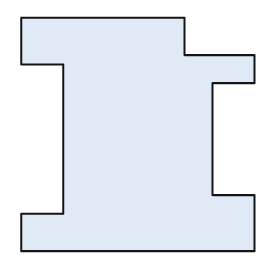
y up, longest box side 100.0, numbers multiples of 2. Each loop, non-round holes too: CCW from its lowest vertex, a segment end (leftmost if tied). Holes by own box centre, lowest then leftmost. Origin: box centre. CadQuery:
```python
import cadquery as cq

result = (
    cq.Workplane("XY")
    .moveTo(-50.0, -50.0)
    .lineTo(50.0, -50.0)
    .lineTo(50.0, -26.0)
    .lineTo(32.0, -26.0)
    .lineTo(32.0, 22.0)
    .lineTo(50.0, 22.0)
    .lineTo(50.0, 34.0)
    .lineTo(20.0, 34.0)
    .lineTo(20.0, 50.0)
    .lineTo(-50.0, 50.0)
    .lineTo(-50.0, 30.0)
    .lineTo(-32.0, 30.0)
    .lineTo(-32.0, -34.0)
    .lineTo(-50.0, -34.0)
    .close()
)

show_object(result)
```